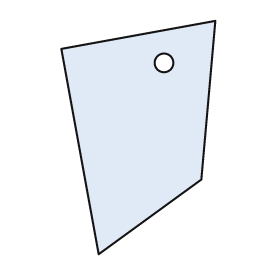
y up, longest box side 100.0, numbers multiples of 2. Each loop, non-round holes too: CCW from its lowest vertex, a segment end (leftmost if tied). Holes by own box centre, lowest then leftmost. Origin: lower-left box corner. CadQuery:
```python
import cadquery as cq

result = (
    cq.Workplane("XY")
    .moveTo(16.0, 0.0)
    .lineTo(60.0, 32.0)
    .lineTo(66.0, 100.0)
    .lineTo(0.0, 88.0)
    .close()
    .moveTo(44.0, 82.0)
    .circle(4.0)
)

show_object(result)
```